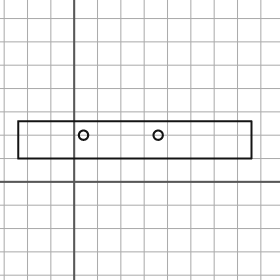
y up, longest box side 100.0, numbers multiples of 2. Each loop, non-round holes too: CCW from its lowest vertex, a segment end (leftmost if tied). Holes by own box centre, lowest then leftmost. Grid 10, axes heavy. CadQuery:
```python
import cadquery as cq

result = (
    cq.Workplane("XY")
    .moveTo(-24.0, 10.0)
    .lineTo(76.0, 10.0)
    .lineTo(76.0, 26.0)
    .lineTo(-24.0, 26.0)
    .close()
    .moveTo(4.0, 20.0)
    .circle(2.0)
    .moveTo(36.0, 20.0)
    .circle(2.0)
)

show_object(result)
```